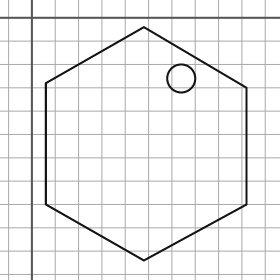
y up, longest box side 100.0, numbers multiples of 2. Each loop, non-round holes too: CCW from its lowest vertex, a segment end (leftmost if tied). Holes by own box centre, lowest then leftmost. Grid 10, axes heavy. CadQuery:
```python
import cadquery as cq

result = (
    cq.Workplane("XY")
    .moveTo(48.0, -104.0)
    .lineTo(92.0, -80.0)
    .lineTo(92.0, -30.0)
    .lineTo(48.0, -4.0)
    .lineTo(6.0, -28.0)
    .lineTo(6.0, -80.0)
    .close()
    .moveTo(64.0, -26.0)
    .circle(6.0)
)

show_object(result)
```